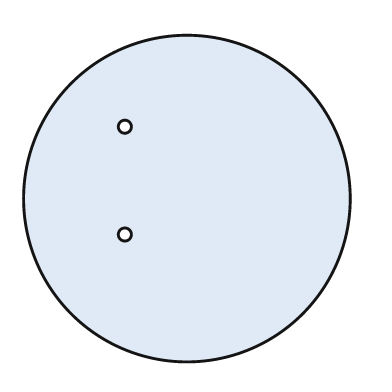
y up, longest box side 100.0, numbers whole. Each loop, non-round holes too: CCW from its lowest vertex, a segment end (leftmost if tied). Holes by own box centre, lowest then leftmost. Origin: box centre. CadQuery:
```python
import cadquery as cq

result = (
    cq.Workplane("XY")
    .moveTo(0.0, 0.0)
    .circle(50.0)
    .moveTo(-19.0, -11.0)
    .circle(2.0)
    .moveTo(-19.0, 22.0)
    .circle(2.0)
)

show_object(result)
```